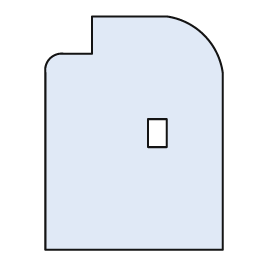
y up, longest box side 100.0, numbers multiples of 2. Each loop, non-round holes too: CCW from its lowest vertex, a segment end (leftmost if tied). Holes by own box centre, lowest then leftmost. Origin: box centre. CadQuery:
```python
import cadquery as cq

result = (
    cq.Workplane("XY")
    .moveTo(-38.0, -50.0)
    .lineTo(38.0, -50.0)
    .lineTo(38.0, 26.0)
    .threePointArc((30.0, 42.0), (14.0, 50.0))
    .lineTo(-18.0, 50.0)
    .lineTo(-18.0, 34.0)
    .lineTo(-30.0, 34.0)
    .threePointArc((-36.0, 32.0), (-38.0, 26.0))
    .close()
    .moveTo(6.0, -6.0)
    .lineTo(14.0, -6.0)
    .lineTo(14.0, 6.0)
    .lineTo(6.0, 6.0)
    .close()
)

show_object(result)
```